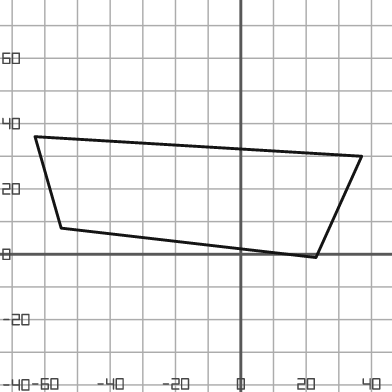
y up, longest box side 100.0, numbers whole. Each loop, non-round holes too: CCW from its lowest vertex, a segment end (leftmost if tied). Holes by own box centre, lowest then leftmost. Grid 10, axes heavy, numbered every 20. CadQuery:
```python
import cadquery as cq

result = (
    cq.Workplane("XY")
    .moveTo(23.0, -1.0)
    .lineTo(37.0, 30.0)
    .lineTo(-63.0, 36.0)
    .lineTo(-55.0, 8.0)
    .close()
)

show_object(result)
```